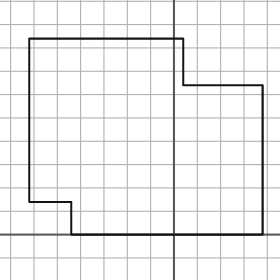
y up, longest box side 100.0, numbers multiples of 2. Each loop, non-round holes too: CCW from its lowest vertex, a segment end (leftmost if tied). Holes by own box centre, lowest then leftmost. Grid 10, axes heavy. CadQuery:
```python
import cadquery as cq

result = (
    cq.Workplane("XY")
    .moveTo(-44.0, 0.0)
    .lineTo(38.0, 0.0)
    .lineTo(38.0, 64.0)
    .lineTo(4.0, 64.0)
    .lineTo(4.0, 84.0)
    .lineTo(-62.0, 84.0)
    .lineTo(-62.0, 14.0)
    .lineTo(-44.0, 14.0)
    .close()
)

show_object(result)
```